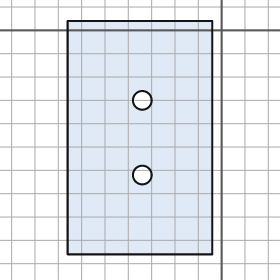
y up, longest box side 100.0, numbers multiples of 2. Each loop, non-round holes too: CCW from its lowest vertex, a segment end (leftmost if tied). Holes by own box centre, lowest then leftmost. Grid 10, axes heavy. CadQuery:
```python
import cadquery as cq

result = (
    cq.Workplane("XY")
    .moveTo(-66.0, -96.0)
    .lineTo(-4.0, -96.0)
    .lineTo(-4.0, 4.0)
    .lineTo(-66.0, 4.0)
    .close()
    .moveTo(-34.0, -62.0)
    .circle(4.0)
    .moveTo(-34.0, -30.0)
    .circle(4.0)
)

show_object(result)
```